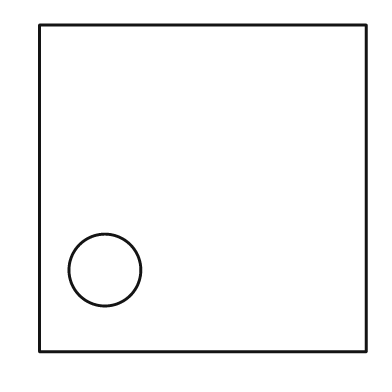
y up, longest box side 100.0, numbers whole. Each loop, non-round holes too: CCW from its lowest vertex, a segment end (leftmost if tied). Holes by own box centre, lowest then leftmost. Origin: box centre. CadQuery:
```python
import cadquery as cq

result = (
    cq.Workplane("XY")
    .moveTo(-50.0, -50.0)
    .lineTo(50.0, -50.0)
    .lineTo(50.0, 50.0)
    .lineTo(-50.0, 50.0)
    .close()
    .moveTo(-30.0, -25.0)
    .circle(11.0)
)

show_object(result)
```